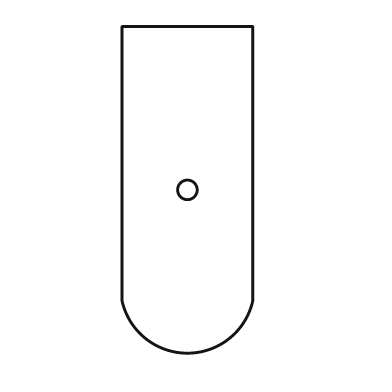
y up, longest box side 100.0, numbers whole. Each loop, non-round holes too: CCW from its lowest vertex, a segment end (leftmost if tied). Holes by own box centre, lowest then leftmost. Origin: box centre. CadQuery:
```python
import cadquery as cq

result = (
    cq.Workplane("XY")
    .moveTo(-20.0, -34.0)
    .threePointArc((0.0, -50.0), (20.0, -34.0))
    .lineTo(20.0, 50.0)
    .lineTo(-20.0, 50.0)
    .close()
    .moveTo(0.0, 0.0)
    .circle(3.0)
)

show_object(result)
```